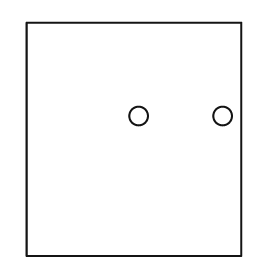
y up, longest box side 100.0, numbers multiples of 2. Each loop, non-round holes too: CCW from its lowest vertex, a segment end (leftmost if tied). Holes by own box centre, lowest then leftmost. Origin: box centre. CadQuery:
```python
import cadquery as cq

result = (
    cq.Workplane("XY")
    .moveTo(-46.0, -50.0)
    .lineTo(46.0, -50.0)
    .lineTo(46.0, 50.0)
    .lineTo(-46.0, 50.0)
    .close()
    .moveTo(2.0, 10.0)
    .circle(4.0)
    .moveTo(38.0, 10.0)
    .circle(4.0)
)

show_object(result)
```